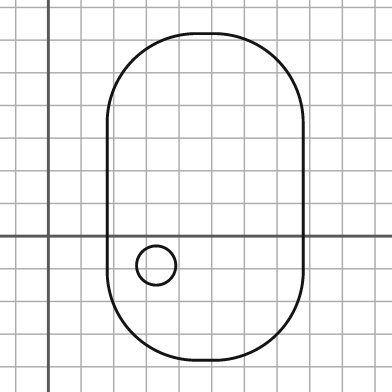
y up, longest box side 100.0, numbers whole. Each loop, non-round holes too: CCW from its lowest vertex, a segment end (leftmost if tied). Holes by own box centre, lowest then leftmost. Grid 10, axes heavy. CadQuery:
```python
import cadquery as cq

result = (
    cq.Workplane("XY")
    .moveTo(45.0, -38.0)
    .lineTo(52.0, -38.0)
    .threePointArc((70.0, -30.0), (78.0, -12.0))
    .lineTo(78.0, 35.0)
    .threePointArc((70.0, 54.0), (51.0, 62.0))
    .lineTo(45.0, 62.0)
    .threePointArc((26.0, 54.0), (18.0, 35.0))
    .lineTo(18.0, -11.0)
    .threePointArc((26.0, -30.0), (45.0, -38.0))
    .close()
    .moveTo(33.0, -9.0)
    .circle(6.0)
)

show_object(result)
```